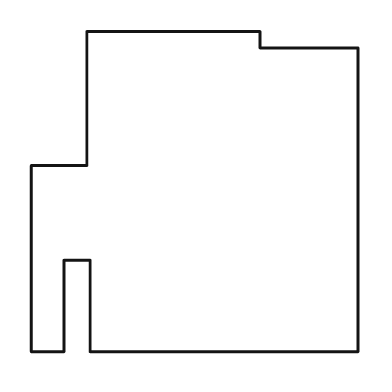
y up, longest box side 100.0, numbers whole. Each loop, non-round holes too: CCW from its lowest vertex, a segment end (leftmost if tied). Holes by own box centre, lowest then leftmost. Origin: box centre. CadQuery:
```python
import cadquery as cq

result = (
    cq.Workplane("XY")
    .moveTo(-50.0, -49.0)
    .lineTo(-40.0, -49.0)
    .lineTo(-40.0, -21.0)
    .lineTo(-32.0, -21.0)
    .lineTo(-32.0, -49.0)
    .lineTo(50.0, -49.0)
    .lineTo(50.0, 44.0)
    .lineTo(20.0, 44.0)
    .lineTo(20.0, 49.0)
    .lineTo(-33.0, 49.0)
    .lineTo(-33.0, 8.0)
    .lineTo(-50.0, 8.0)
    .close()
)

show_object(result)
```